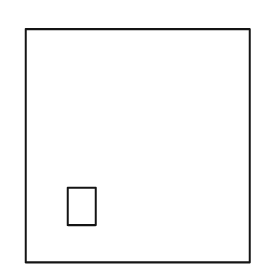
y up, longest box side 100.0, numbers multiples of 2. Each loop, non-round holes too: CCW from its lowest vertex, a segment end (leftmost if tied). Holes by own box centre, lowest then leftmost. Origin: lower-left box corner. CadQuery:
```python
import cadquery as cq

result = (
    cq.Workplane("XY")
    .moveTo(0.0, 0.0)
    .lineTo(96.0, 0.0)
    .lineTo(96.0, 100.0)
    .lineTo(0.0, 100.0)
    .close()
    .moveTo(18.0, 16.0)
    .lineTo(30.0, 16.0)
    .lineTo(30.0, 32.0)
    .lineTo(18.0, 32.0)
    .close()
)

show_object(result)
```